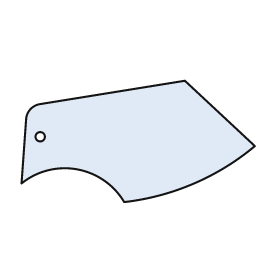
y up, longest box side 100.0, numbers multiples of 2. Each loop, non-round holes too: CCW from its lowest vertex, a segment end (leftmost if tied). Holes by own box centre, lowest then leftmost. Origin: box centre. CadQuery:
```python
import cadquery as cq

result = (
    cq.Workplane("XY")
    .moveTo(-6.0, -26.0)
    .threePointArc((24.0, -18.0), (50.0, -2.0))
    .lineTo(20.0, 26.0)
    .lineTo(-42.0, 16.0)
    .threePointArc((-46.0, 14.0), (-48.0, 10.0))
    .lineTo(-50.0, -18.0)
    .threePointArc((-26.0, -12.0), (-6.0, -26.0))
    .close()
    .moveTo(-42.0, 2.0)
    .circle(2.0)
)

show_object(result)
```